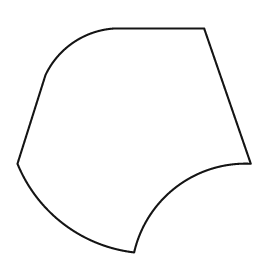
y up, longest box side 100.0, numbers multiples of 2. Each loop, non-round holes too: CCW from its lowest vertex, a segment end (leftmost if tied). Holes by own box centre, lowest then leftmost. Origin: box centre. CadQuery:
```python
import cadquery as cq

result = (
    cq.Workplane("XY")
    .moveTo(0.0, -48.0)
    .threePointArc((18.0, -20.0), (50.0, -10.0))
    .lineTo(30.0, 48.0)
    .lineTo(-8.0, 48.0)
    .threePointArc((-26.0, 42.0), (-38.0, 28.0))
    .lineTo(-50.0, -10.0)
    .threePointArc((-30.0, -36.0), (0.0, -48.0))
    .close()
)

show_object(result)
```